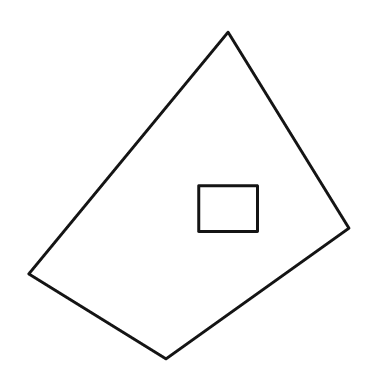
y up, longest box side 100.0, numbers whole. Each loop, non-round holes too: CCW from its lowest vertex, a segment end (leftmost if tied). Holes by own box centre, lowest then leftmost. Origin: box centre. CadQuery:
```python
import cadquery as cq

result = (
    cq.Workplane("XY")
    .moveTo(-7.0, -50.0)
    .lineTo(49.0, -10.0)
    .lineTo(12.0, 50.0)
    .lineTo(-49.0, -24.0)
    .close()
    .moveTo(3.0, -11.0)
    .lineTo(21.0, -11.0)
    .lineTo(21.0, 3.0)
    .lineTo(3.0, 3.0)
    .close()
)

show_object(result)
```